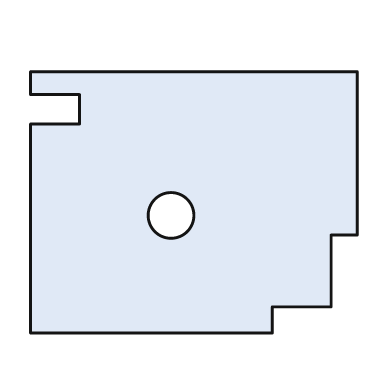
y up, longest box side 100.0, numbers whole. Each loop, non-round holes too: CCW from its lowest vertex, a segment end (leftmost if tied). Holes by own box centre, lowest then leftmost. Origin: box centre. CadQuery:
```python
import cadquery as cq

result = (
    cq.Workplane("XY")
    .moveTo(-50.0, -40.0)
    .lineTo(24.0, -40.0)
    .lineTo(24.0, -32.0)
    .lineTo(42.0, -32.0)
    .lineTo(42.0, -10.0)
    .lineTo(50.0, -10.0)
    .lineTo(50.0, 40.0)
    .lineTo(-50.0, 40.0)
    .lineTo(-50.0, 33.0)
    .lineTo(-35.0, 33.0)
    .lineTo(-35.0, 24.0)
    .lineTo(-50.0, 24.0)
    .close()
    .moveTo(-7.0, -4.0)
    .circle(7.0)
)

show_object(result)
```